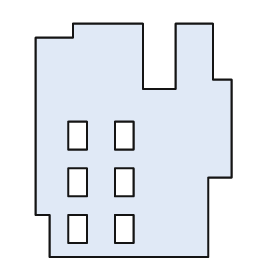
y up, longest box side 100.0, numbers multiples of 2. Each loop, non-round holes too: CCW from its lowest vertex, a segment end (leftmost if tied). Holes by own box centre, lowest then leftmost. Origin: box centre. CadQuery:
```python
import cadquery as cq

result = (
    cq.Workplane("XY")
    .moveTo(-36.0, -50.0)
    .lineTo(32.0, -50.0)
    .lineTo(32.0, -16.0)
    .lineTo(42.0, -16.0)
    .lineTo(42.0, 26.0)
    .lineTo(34.0, 26.0)
    .lineTo(34.0, 50.0)
    .lineTo(18.0, 50.0)
    .lineTo(18.0, 22.0)
    .lineTo(4.0, 22.0)
    .lineTo(4.0, 50.0)
    .lineTo(-26.0, 50.0)
    .lineTo(-26.0, 44.0)
    .lineTo(-42.0, 44.0)
    .lineTo(-42.0, -32.0)
    .lineTo(-36.0, -32.0)
    .close()
    .moveTo(-28.0, -44.0)
    .lineTo(-20.0, -44.0)
    .lineTo(-20.0, -32.0)
    .lineTo(-28.0, -32.0)
    .close()
    .moveTo(-8.0, -44.0)
    .lineTo(0.0, -44.0)
    .lineTo(0.0, -32.0)
    .lineTo(-8.0, -32.0)
    .close()
    .moveTo(-28.0, -24.0)
    .lineTo(-20.0, -24.0)
    .lineTo(-20.0, -12.0)
    .lineTo(-28.0, -12.0)
    .close()
    .moveTo(-8.0, -24.0)
    .lineTo(0.0, -24.0)
    .lineTo(0.0, -12.0)
    .lineTo(-8.0, -12.0)
    .close()
    .moveTo(-28.0, -4.0)
    .lineTo(-20.0, -4.0)
    .lineTo(-20.0, 8.0)
    .lineTo(-28.0, 8.0)
    .close()
    .moveTo(-8.0, -4.0)
    .lineTo(0.0, -4.0)
    .lineTo(0.0, 8.0)
    .lineTo(-8.0, 8.0)
    .close()
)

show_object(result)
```